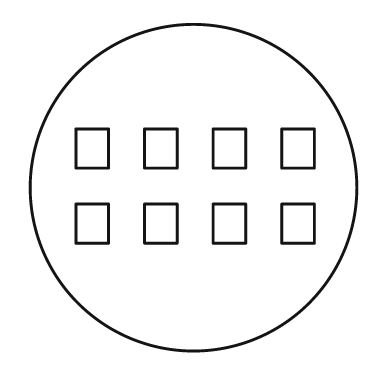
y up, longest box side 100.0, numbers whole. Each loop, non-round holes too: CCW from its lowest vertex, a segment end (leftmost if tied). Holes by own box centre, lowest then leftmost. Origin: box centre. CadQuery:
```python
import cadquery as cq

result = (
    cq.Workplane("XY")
    .moveTo(0.0, 0.0)
    .circle(50.0)
    .moveTo(-36.0, -17.0)
    .lineTo(-26.0, -17.0)
    .lineTo(-26.0, -5.0)
    .lineTo(-36.0, -5.0)
    .close()
    .moveTo(-15.0, -17.0)
    .lineTo(-5.0, -17.0)
    .lineTo(-5.0, -5.0)
    .lineTo(-15.0, -5.0)
    .close()
    .moveTo(6.0, -17.0)
    .lineTo(16.0, -17.0)
    .lineTo(16.0, -5.0)
    .lineTo(6.0, -5.0)
    .close()
    .moveTo(27.0, -17.0)
    .lineTo(37.0, -17.0)
    .lineTo(37.0, -5.0)
    .lineTo(27.0, -5.0)
    .close()
    .moveTo(-36.0, 6.0)
    .lineTo(-26.0, 6.0)
    .lineTo(-26.0, 18.0)
    .lineTo(-36.0, 18.0)
    .close()
    .moveTo(-15.0, 6.0)
    .lineTo(-5.0, 6.0)
    .lineTo(-5.0, 18.0)
    .lineTo(-15.0, 18.0)
    .close()
    .moveTo(6.0, 6.0)
    .lineTo(16.0, 6.0)
    .lineTo(16.0, 18.0)
    .lineTo(6.0, 18.0)
    .close()
    .moveTo(27.0, 6.0)
    .lineTo(37.0, 6.0)
    .lineTo(37.0, 18.0)
    .lineTo(27.0, 18.0)
    .close()
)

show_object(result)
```